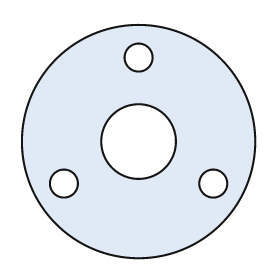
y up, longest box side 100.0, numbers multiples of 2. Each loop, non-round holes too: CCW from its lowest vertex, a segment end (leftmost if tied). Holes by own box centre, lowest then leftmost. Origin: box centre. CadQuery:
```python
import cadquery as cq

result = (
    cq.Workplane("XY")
    .moveTo(0.0, 0.0)
    .circle(50.0)
    .moveTo(-32.0, -18.0)
    .circle(6.0)
    .moveTo(32.0, -18.0)
    .circle(6.0)
    .moveTo(0.0, 0.0)
    .circle(16.0)
    .moveTo(0.0, 36.0)
    .circle(6.0)
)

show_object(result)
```